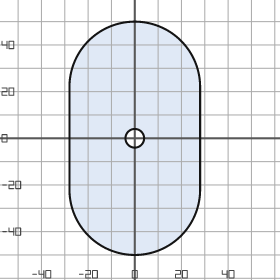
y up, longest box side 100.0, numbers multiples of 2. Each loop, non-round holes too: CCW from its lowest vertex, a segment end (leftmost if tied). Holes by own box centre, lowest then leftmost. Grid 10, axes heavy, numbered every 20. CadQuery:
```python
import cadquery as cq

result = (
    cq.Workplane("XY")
    .moveTo(-28.0, -22.0)
    .threePointArc((0.0, -50.0), (28.0, -22.0))
    .lineTo(28.0, 22.0)
    .threePointArc((0.0, 50.0), (-28.0, 22.0))
    .close()
    .moveTo(0.0, 0.0)
    .circle(4.0)
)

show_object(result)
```